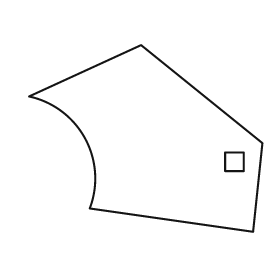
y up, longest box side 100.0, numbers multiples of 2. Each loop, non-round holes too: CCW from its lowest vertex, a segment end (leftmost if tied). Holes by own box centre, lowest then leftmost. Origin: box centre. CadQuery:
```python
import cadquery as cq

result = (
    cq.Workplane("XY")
    .moveTo(46.0, -40.0)
    .lineTo(50.0, -2.0)
    .lineTo(-2.0, 40.0)
    .lineTo(-50.0, 18.0)
    .threePointArc((-26.0, 0.0), (-24.0, -30.0))
    .close()
    .moveTo(34.0, -14.0)
    .lineTo(42.0, -14.0)
    .lineTo(42.0, -6.0)
    .lineTo(34.0, -6.0)
    .close()
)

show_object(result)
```